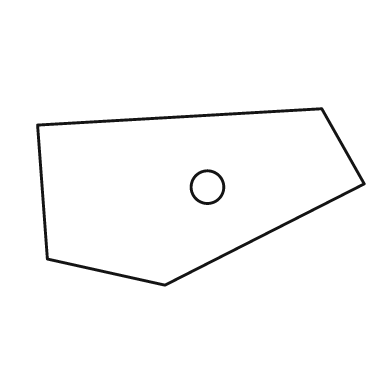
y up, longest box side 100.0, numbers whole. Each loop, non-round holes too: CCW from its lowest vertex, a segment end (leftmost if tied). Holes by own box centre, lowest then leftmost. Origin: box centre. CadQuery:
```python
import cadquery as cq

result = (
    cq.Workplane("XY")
    .moveTo(-11.0, -27.0)
    .lineTo(50.0, 4.0)
    .lineTo(37.0, 27.0)
    .lineTo(-50.0, 22.0)
    .lineTo(-47.0, -19.0)
    .close()
    .moveTo(2.0, 3.0)
    .circle(5.0)
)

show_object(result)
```